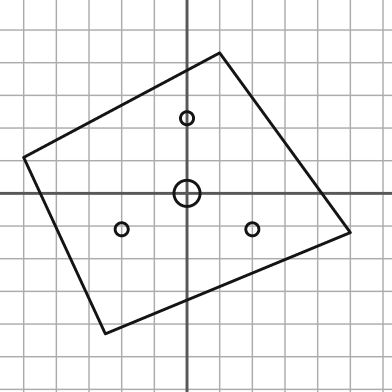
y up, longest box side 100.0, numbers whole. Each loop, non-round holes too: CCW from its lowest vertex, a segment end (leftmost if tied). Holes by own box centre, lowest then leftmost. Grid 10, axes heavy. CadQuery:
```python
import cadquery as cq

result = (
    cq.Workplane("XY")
    .moveTo(-25.0, -43.0)
    .lineTo(50.0, -12.0)
    .lineTo(10.0, 43.0)
    .lineTo(-50.0, 11.0)
    .close()
    .moveTo(-20.0, -11.0)
    .circle(2.0)
    .moveTo(20.0, -11.0)
    .circle(2.0)
    .moveTo(0.0, 0.0)
    .circle(4.0)
    .moveTo(0.0, 23.0)
    .circle(2.0)
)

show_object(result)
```